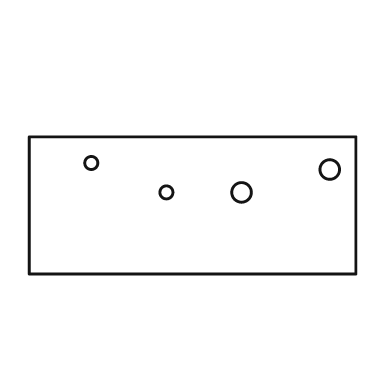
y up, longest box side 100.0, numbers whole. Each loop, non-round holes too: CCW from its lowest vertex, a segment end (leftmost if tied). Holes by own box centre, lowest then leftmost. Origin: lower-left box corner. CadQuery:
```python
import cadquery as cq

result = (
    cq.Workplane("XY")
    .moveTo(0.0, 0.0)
    .lineTo(100.0, 0.0)
    .lineTo(100.0, 42.0)
    .lineTo(0.0, 42.0)
    .close()
    .moveTo(42.0, 25.0)
    .circle(2.0)
    .moveTo(65.0, 25.0)
    .circle(3.0)
    .moveTo(92.0, 32.0)
    .circle(3.0)
    .moveTo(19.0, 34.0)
    .circle(2.0)
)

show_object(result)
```